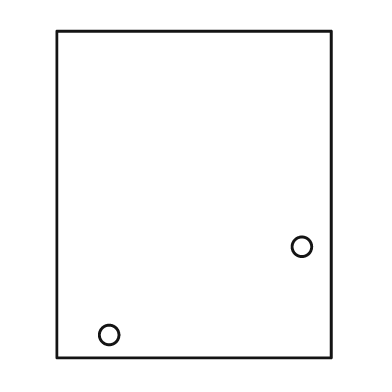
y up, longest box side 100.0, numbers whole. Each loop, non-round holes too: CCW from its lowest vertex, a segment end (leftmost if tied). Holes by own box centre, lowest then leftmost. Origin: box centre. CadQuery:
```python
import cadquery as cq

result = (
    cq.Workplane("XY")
    .moveTo(-42.0, -50.0)
    .lineTo(42.0, -50.0)
    .lineTo(42.0, 50.0)
    .lineTo(-42.0, 50.0)
    .close()
    .moveTo(-26.0, -43.0)
    .circle(3.0)
    .moveTo(33.0, -16.0)
    .circle(3.0)
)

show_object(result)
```